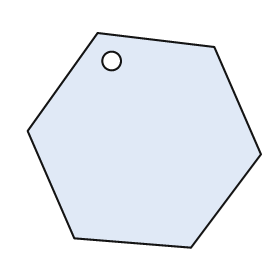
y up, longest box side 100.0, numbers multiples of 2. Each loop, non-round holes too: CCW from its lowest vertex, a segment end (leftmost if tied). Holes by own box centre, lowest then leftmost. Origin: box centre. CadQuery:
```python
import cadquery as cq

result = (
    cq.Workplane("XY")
    .moveTo(20.0, -46.0)
    .lineTo(50.0, -6.0)
    .lineTo(30.0, 40.0)
    .lineTo(-20.0, 46.0)
    .lineTo(-50.0, 4.0)
    .lineTo(-30.0, -42.0)
    .close()
    .moveTo(-14.0, 34.0)
    .circle(4.0)
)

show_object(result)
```